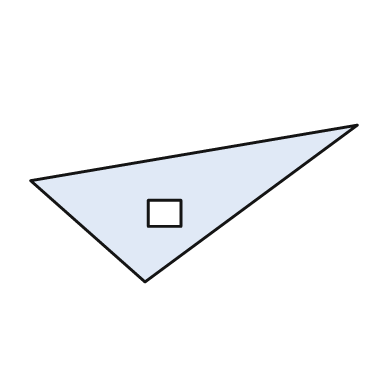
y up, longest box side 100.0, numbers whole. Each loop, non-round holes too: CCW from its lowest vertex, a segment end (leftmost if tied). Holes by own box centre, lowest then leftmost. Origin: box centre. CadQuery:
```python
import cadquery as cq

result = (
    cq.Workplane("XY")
    .moveTo(-15.0, -24.0)
    .lineTo(50.0, 24.0)
    .lineTo(-50.0, 7.0)
    .close()
    .moveTo(-14.0, -7.0)
    .lineTo(-4.0, -7.0)
    .lineTo(-4.0, 1.0)
    .lineTo(-14.0, 1.0)
    .close()
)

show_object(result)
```